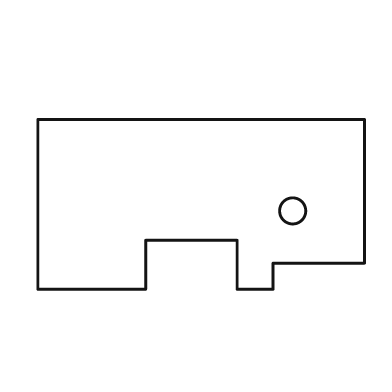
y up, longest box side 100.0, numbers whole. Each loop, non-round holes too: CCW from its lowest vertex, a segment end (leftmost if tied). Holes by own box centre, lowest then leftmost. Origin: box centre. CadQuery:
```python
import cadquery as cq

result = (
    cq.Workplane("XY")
    .moveTo(-50.0, -26.0)
    .lineTo(-17.0, -26.0)
    .lineTo(-17.0, -11.0)
    .lineTo(11.0, -11.0)
    .lineTo(11.0, -26.0)
    .lineTo(22.0, -26.0)
    .lineTo(22.0, -18.0)
    .lineTo(50.0, -18.0)
    .lineTo(50.0, 26.0)
    .lineTo(-50.0, 26.0)
    .close()
    .moveTo(28.0, -2.0)
    .circle(4.0)
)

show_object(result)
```